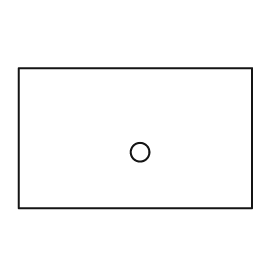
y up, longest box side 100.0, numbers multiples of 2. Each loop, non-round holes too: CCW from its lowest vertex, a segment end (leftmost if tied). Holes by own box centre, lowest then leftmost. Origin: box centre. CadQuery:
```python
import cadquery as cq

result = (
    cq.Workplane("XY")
    .moveTo(-50.0, -30.0)
    .lineTo(50.0, -30.0)
    .lineTo(50.0, 30.0)
    .lineTo(-50.0, 30.0)
    .close()
    .moveTo(2.0, -6.0)
    .circle(4.0)
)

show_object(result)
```